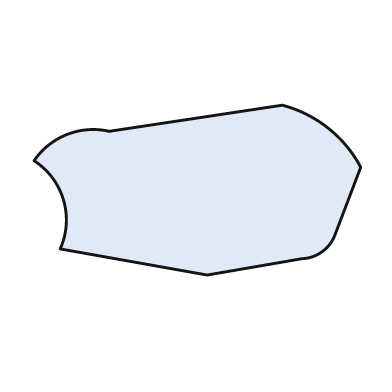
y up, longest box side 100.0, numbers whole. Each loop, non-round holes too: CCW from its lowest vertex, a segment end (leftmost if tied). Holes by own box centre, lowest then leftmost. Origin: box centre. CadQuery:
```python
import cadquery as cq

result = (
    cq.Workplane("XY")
    .moveTo(3.0, -26.0)
    .lineTo(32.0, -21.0)
    .threePointArc((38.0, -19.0), (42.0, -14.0))
    .lineTo(50.0, 7.0)
    .threePointArc((40.0, 19.0), (26.0, 26.0))
    .lineTo(-27.0, 18.0)
    .threePointArc((-40.0, 17.0), (-50.0, 9.0))
    .threePointArc((-41.0, -3.0), (-42.0, -18.0))
    .close()
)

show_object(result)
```